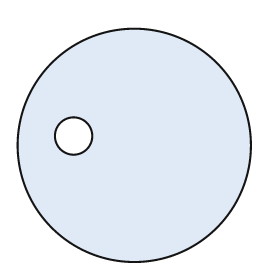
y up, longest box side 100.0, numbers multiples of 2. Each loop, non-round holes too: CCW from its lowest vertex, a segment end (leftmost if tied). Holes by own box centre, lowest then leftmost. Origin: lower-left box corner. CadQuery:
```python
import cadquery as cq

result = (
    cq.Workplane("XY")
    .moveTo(50.0, 50.0)
    .circle(50.0)
    .moveTo(24.0, 54.0)
    .circle(8.0)
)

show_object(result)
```